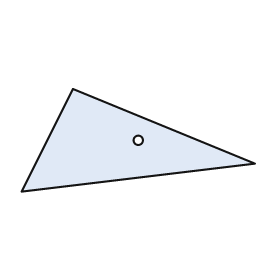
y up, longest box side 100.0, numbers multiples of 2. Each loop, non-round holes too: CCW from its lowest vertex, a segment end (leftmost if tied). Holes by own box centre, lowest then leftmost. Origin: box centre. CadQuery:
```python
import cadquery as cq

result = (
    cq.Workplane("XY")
    .moveTo(-50.0, -22.0)
    .lineTo(50.0, -10.0)
    .lineTo(-28.0, 22.0)
    .close()
    .moveTo(0.0, 0.0)
    .circle(2.0)
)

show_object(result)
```